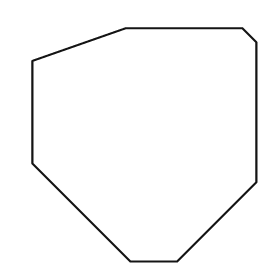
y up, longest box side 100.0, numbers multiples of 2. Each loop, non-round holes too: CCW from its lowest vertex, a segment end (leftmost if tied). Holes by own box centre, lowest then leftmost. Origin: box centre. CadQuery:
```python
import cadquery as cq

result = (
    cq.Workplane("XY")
    .moveTo(-6.0, -50.0)
    .lineTo(14.0, -50.0)
    .lineTo(48.0, -16.0)
    .lineTo(48.0, 44.0)
    .lineTo(42.0, 50.0)
    .lineTo(-8.0, 50.0)
    .lineTo(-48.0, 36.0)
    .lineTo(-48.0, -8.0)
    .close()
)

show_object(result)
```